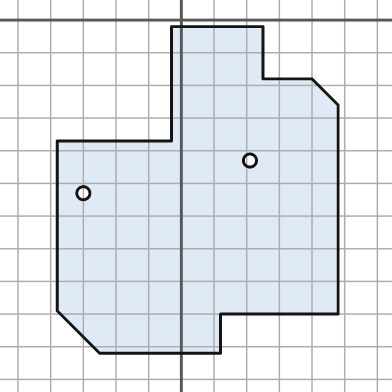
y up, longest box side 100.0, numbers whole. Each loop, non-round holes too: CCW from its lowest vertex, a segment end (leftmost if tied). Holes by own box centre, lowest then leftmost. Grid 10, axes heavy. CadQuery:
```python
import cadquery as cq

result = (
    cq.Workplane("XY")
    .moveTo(-25.0, -102.0)
    .lineTo(12.0, -102.0)
    .lineTo(12.0, -90.0)
    .lineTo(48.0, -90.0)
    .lineTo(48.0, -26.0)
    .lineTo(40.0, -18.0)
    .lineTo(25.0, -18.0)
    .lineTo(25.0, -2.0)
    .lineTo(-3.0, -2.0)
    .lineTo(-3.0, -37.0)
    .lineTo(-38.0, -37.0)
    .lineTo(-38.0, -89.0)
    .close()
    .moveTo(-30.0, -53.0)
    .circle(2.0)
    .moveTo(21.0, -43.0)
    .circle(2.0)
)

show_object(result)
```